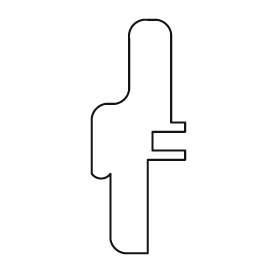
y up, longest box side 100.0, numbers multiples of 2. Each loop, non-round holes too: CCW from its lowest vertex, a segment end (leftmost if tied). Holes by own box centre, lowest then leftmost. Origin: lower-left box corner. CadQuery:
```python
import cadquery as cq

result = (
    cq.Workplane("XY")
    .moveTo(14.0, 0.0)
    .lineTo(24.0, 0.0)
    .lineTo(24.0, 40.0)
    .lineTo(40.0, 40.0)
    .lineTo(40.0, 44.0)
    .lineTo(26.0, 44.0)
    .lineTo(26.0, 52.0)
    .lineTo(40.0, 52.0)
    .lineTo(40.0, 56.0)
    .lineTo(34.0, 56.0)
    .lineTo(34.0, 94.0)
    .threePointArc((32.0, 98.0), (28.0, 100.0))
    .lineTo(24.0, 100.0)
    .threePointArc((18.0, 98.0), (16.0, 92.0))
    .lineTo(16.0, 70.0)
    .threePointArc((14.0, 66.0), (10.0, 64.0))
    .lineTo(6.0, 64.0)
    .threePointArc((2.0, 62.0), (0.0, 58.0))
    .lineTo(0.0, 34.0)
    .threePointArc((4.0, 32.0), (8.0, 34.0))
    .lineTo(8.0, 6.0)
    .threePointArc((10.0, 2.0), (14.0, 0.0))
    .close()
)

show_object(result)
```